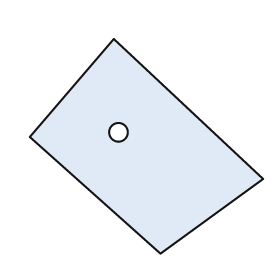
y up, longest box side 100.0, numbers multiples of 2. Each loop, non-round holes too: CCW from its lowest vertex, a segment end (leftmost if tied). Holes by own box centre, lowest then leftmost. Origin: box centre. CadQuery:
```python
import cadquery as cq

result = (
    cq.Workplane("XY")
    .moveTo(6.0, -46.0)
    .lineTo(50.0, -14.0)
    .lineTo(-14.0, 46.0)
    .lineTo(-50.0, 4.0)
    .close()
    .moveTo(-12.0, 6.0)
    .circle(4.0)
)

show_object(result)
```